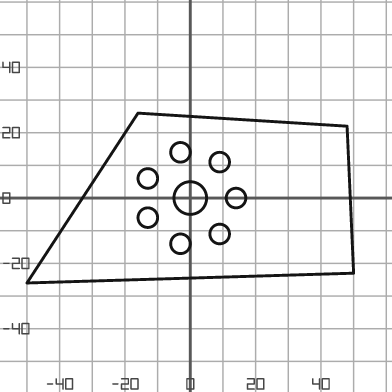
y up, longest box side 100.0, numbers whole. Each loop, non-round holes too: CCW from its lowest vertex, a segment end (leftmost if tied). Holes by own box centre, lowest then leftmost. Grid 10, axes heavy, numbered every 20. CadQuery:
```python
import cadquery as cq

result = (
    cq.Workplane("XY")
    .moveTo(-50.0, -26.0)
    .lineTo(50.0, -23.0)
    .lineTo(48.0, 22.0)
    .lineTo(-16.0, 26.0)
    .close()
    .moveTo(-3.0, -14.0)
    .circle(3.0)
    .moveTo(9.0, -11.0)
    .circle(3.0)
    .moveTo(-13.0, -6.0)
    .circle(3.0)
    .moveTo(0.0, 0.0)
    .circle(5.0)
    .moveTo(14.0, 0.0)
    .circle(3.0)
    .moveTo(-13.0, 6.0)
    .circle(3.0)
    .moveTo(9.0, 11.0)
    .circle(3.0)
    .moveTo(-3.0, 14.0)
    .circle(3.0)
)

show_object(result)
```